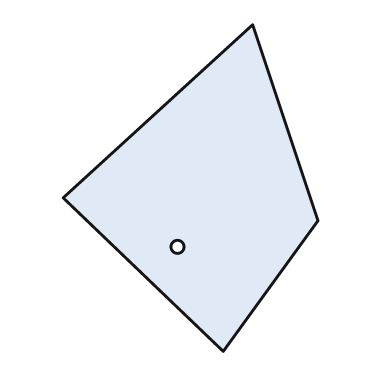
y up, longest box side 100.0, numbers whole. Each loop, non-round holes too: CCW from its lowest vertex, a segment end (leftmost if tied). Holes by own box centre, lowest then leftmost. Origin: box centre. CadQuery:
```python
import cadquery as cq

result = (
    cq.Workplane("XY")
    .moveTo(10.0, -50.0)
    .lineTo(39.0, -10.0)
    .lineTo(19.0, 50.0)
    .lineTo(-39.0, -3.0)
    .close()
    .moveTo(-4.0, -18.0)
    .circle(2.0)
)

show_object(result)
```